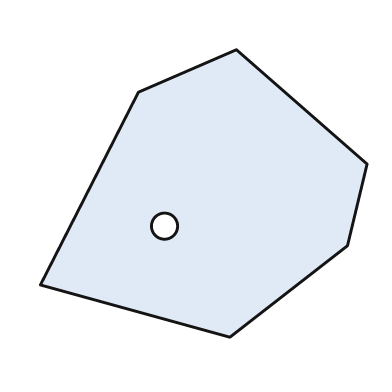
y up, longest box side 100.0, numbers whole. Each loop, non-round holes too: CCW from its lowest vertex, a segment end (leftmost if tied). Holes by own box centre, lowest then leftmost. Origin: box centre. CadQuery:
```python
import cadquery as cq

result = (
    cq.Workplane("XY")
    .moveTo(8.0, -44.0)
    .lineTo(44.0, -16.0)
    .lineTo(50.0, 9.0)
    .lineTo(10.0, 44.0)
    .lineTo(-20.0, 31.0)
    .lineTo(-50.0, -28.0)
    .close()
    .moveTo(-12.0, -10.0)
    .circle(4.0)
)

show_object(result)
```